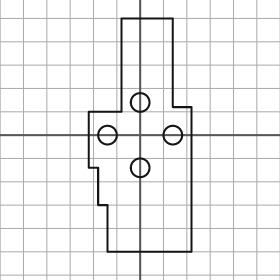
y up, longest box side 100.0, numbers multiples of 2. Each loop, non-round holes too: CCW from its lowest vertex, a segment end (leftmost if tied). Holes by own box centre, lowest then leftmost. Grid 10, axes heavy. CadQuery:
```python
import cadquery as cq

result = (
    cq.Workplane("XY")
    .moveTo(-14.0, -50.0)
    .lineTo(22.0, -50.0)
    .lineTo(22.0, 12.0)
    .lineTo(14.0, 12.0)
    .lineTo(14.0, 50.0)
    .lineTo(-8.0, 50.0)
    .lineTo(-8.0, 10.0)
    .lineTo(-22.0, 10.0)
    .lineTo(-22.0, -14.0)
    .lineTo(-18.0, -14.0)
    .lineTo(-18.0, -30.0)
    .lineTo(-14.0, -30.0)
    .close()
    .moveTo(0.0, -14.0)
    .circle(4.0)
    .moveTo(-14.0, 0.0)
    .circle(4.0)
    .moveTo(14.0, 0.0)
    .circle(4.0)
    .moveTo(0.0, 14.0)
    .circle(4.0)
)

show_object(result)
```